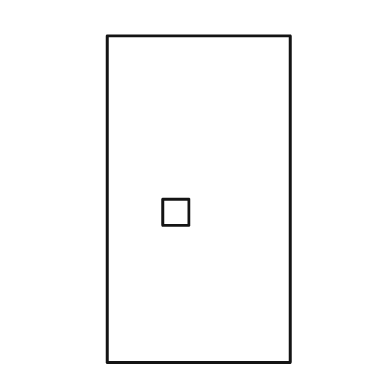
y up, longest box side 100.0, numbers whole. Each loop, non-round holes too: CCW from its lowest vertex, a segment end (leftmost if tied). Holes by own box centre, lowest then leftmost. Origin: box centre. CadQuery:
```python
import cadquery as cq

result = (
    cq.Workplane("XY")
    .moveTo(-28.0, -50.0)
    .lineTo(28.0, -50.0)
    .lineTo(28.0, 50.0)
    .lineTo(-28.0, 50.0)
    .close()
    .moveTo(-11.0, -8.0)
    .lineTo(-3.0, -8.0)
    .lineTo(-3.0, 0.0)
    .lineTo(-11.0, 0.0)
    .close()
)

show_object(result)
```